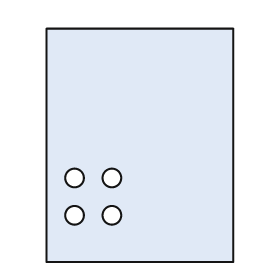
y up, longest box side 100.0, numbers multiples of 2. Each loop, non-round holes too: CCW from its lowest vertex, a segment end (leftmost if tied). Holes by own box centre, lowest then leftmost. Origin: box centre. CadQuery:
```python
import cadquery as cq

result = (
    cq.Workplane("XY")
    .moveTo(-40.0, -50.0)
    .lineTo(40.0, -50.0)
    .lineTo(40.0, 50.0)
    .lineTo(-40.0, 50.0)
    .close()
    .moveTo(-28.0, -30.0)
    .circle(4.0)
    .moveTo(-12.0, -30.0)
    .circle(4.0)
    .moveTo(-28.0, -14.0)
    .circle(4.0)
    .moveTo(-12.0, -14.0)
    .circle(4.0)
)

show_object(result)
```